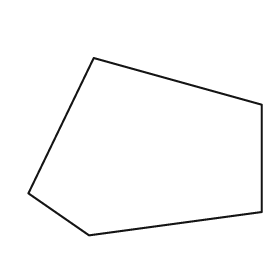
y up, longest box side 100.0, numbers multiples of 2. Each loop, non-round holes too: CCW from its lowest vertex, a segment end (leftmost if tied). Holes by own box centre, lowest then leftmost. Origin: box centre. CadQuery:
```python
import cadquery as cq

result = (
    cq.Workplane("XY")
    .moveTo(-24.0, -38.0)
    .lineTo(50.0, -28.0)
    .lineTo(50.0, 18.0)
    .lineTo(-22.0, 38.0)
    .lineTo(-50.0, -20.0)
    .close()
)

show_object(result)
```